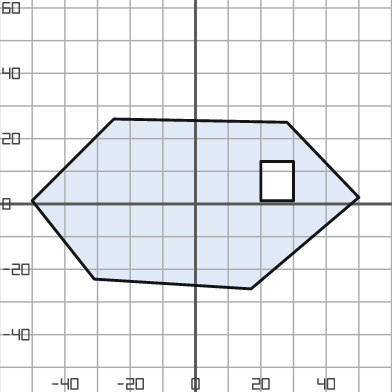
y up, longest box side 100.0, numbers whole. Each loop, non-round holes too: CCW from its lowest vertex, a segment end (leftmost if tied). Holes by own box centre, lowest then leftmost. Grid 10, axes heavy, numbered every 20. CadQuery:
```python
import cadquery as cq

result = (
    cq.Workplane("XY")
    .moveTo(17.0, -26.0)
    .lineTo(50.0, 2.0)
    .lineTo(28.0, 25.0)
    .lineTo(-25.0, 26.0)
    .lineTo(-50.0, 1.0)
    .lineTo(-31.0, -23.0)
    .close()
    .moveTo(20.0, 1.0)
    .lineTo(30.0, 1.0)
    .lineTo(30.0, 13.0)
    .lineTo(20.0, 13.0)
    .close()
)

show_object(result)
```